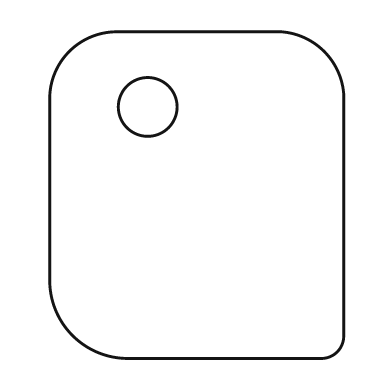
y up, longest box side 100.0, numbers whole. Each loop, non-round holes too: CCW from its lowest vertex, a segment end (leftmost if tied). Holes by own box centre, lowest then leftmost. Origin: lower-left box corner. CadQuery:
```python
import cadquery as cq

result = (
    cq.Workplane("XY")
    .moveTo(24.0, 0.0)
    .lineTo(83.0, 0.0)
    .threePointArc((88.0, 2.0), (90.0, 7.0))
    .lineTo(90.0, 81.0)
    .threePointArc((84.0, 94.0), (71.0, 100.0))
    .lineTo(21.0, 100.0)
    .threePointArc((6.0, 94.0), (0.0, 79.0))
    .lineTo(0.0, 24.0)
    .threePointArc((7.0, 7.0), (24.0, 0.0))
    .close()
    .moveTo(30.0, 77.0)
    .circle(9.0)
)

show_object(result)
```